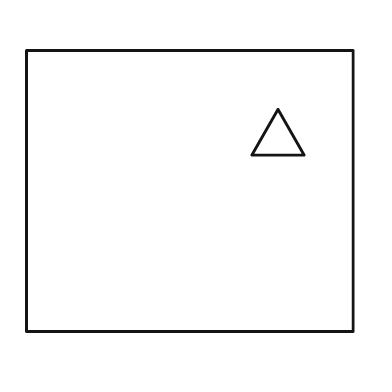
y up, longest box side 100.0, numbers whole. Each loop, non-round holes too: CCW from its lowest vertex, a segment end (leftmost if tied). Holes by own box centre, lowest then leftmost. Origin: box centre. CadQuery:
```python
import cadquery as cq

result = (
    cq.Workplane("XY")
    .moveTo(-50.0, -43.0)
    .lineTo(50.0, -43.0)
    .lineTo(50.0, 43.0)
    .lineTo(-50.0, 43.0)
    .close()
    .moveTo(19.0, 11.0)
    .lineTo(35.0, 11.0)
    .lineTo(27.0, 25.0)
    .close()
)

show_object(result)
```